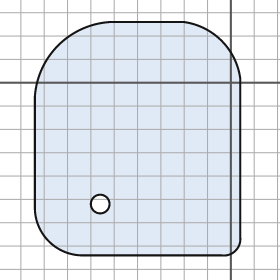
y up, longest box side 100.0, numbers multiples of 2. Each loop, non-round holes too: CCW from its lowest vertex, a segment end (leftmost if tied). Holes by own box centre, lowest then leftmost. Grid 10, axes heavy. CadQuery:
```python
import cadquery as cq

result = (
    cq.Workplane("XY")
    .moveTo(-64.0, -74.0)
    .lineTo(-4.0, -74.0)
    .threePointArc((2.0, -72.0), (4.0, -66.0))
    .lineTo(4.0, 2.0)
    .threePointArc((-4.0, 18.0), (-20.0, 26.0))
    .lineTo(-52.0, 26.0)
    .threePointArc((-74.0, 16.0), (-84.0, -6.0))
    .lineTo(-84.0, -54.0)
    .threePointArc((-78.0, -68.0), (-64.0, -74.0))
    .close()
    .moveTo(-56.0, -52.0)
    .circle(4.0)
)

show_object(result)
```